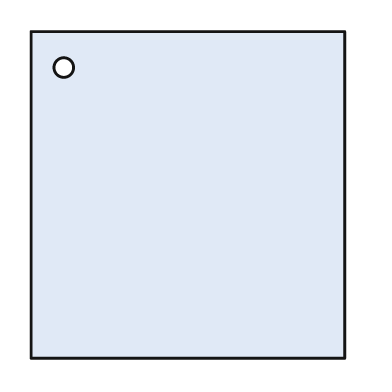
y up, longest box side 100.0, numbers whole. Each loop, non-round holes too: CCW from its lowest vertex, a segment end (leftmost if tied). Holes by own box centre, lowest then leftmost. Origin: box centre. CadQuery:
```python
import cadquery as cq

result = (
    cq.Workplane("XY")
    .moveTo(-48.0, -50.0)
    .lineTo(48.0, -50.0)
    .lineTo(48.0, 50.0)
    .lineTo(-48.0, 50.0)
    .close()
    .moveTo(-38.0, 39.0)
    .circle(3.0)
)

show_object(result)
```